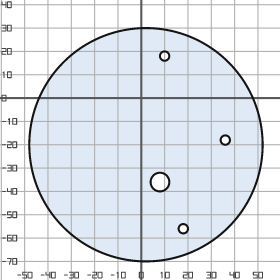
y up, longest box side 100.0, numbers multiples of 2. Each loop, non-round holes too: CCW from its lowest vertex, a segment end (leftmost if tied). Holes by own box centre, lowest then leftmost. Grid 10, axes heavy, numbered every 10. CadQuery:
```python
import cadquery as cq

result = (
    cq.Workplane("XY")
    .moveTo(2.0, -20.0)
    .circle(50.0)
    .moveTo(18.0, -56.0)
    .circle(2.0)
    .moveTo(8.0, -36.0)
    .circle(4.0)
    .moveTo(36.0, -18.0)
    .circle(2.0)
    .moveTo(10.0, 18.0)
    .circle(2.0)
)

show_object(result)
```